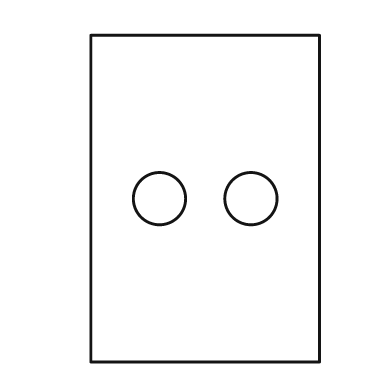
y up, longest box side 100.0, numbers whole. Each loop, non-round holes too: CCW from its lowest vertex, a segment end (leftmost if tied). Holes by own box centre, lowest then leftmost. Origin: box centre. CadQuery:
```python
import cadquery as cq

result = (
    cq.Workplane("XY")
    .moveTo(-35.0, -50.0)
    .lineTo(35.0, -50.0)
    .lineTo(35.0, 50.0)
    .lineTo(-35.0, 50.0)
    .close()
    .moveTo(-14.0, 0.0)
    .circle(8.0)
    .moveTo(14.0, 0.0)
    .circle(8.0)
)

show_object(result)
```